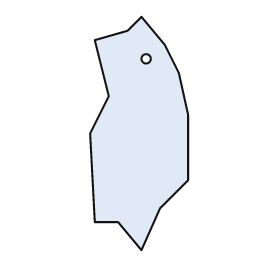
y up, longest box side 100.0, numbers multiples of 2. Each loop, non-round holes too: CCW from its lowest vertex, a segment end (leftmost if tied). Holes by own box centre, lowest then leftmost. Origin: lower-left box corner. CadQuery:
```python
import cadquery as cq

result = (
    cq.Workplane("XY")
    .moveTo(22.0, 0.0)
    .lineTo(30.0, 18.0)
    .lineTo(42.0, 30.0)
    .lineTo(42.0, 58.0)
    .lineTo(38.0, 76.0)
    .lineTo(32.0, 88.0)
    .lineTo(22.0, 100.0)
    .lineTo(16.0, 94.0)
    .lineTo(2.0, 90.0)
    .lineTo(8.0, 66.0)
    .lineTo(0.0, 50.0)
    .lineTo(2.0, 12.0)
    .lineTo(12.0, 12.0)
    .close()
    .moveTo(24.0, 82.0)
    .circle(2.0)
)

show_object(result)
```